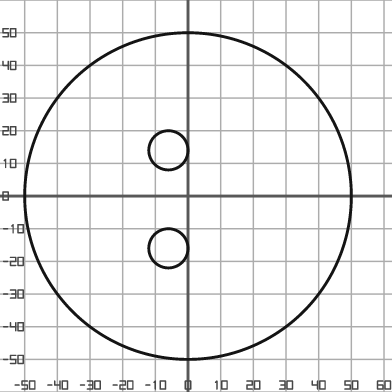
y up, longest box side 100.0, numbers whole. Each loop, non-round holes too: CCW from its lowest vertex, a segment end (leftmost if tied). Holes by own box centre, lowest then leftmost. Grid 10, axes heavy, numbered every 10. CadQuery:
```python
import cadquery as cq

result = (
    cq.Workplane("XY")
    .moveTo(0.0, 0.0)
    .circle(50.0)
    .moveTo(-6.0, -16.0)
    .circle(6.0)
    .moveTo(-6.0, 14.0)
    .circle(6.0)
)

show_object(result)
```